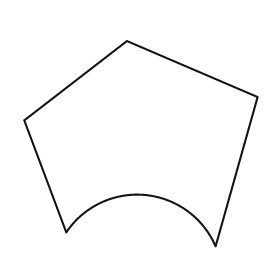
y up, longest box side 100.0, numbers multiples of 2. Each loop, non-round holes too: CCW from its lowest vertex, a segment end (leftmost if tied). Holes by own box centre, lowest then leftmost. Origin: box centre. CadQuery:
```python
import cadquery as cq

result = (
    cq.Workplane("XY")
    .moveTo(32.0, -44.0)
    .lineTo(50.0, 20.0)
    .lineTo(-6.0, 44.0)
    .lineTo(-50.0, 10.0)
    .lineTo(-32.0, -38.0)
    .threePointArc((2.0, -22.0), (32.0, -44.0))
    .close()
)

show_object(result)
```